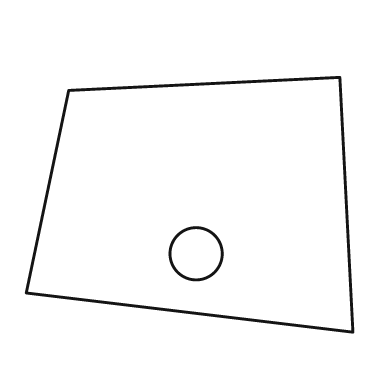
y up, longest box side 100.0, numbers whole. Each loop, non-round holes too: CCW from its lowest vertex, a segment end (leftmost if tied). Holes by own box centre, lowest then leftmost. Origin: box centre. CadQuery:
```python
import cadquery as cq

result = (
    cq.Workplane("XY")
    .moveTo(50.0, -39.0)
    .lineTo(46.0, 39.0)
    .lineTo(-37.0, 35.0)
    .lineTo(-50.0, -27.0)
    .close()
    .moveTo(2.0, -15.0)
    .circle(8.0)
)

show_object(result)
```